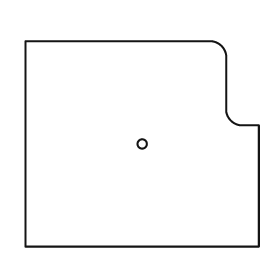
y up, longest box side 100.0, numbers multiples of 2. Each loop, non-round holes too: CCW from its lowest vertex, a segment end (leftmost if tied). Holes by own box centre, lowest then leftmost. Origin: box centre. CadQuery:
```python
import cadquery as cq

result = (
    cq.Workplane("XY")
    .moveTo(-50.0, -44.0)
    .lineTo(50.0, -44.0)
    .lineTo(50.0, 8.0)
    .lineTo(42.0, 8.0)
    .threePointArc((38.0, 10.0), (36.0, 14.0))
    .lineTo(36.0, 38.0)
    .threePointArc((34.0, 42.0), (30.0, 44.0))
    .lineTo(-50.0, 44.0)
    .close()
    .moveTo(0.0, 0.0)
    .circle(2.0)
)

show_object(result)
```